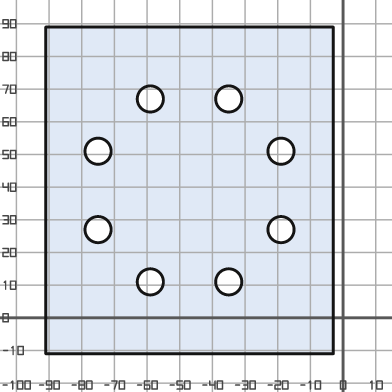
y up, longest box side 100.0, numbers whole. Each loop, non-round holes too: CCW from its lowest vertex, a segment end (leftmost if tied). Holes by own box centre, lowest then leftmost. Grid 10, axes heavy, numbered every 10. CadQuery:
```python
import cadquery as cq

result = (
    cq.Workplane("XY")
    .moveTo(-91.0, -11.0)
    .lineTo(-3.0, -11.0)
    .lineTo(-3.0, 89.0)
    .lineTo(-91.0, 89.0)
    .close()
    .moveTo(-59.0, 11.0)
    .circle(4.0)
    .moveTo(-35.0, 11.0)
    .circle(4.0)
    .moveTo(-75.0, 27.0)
    .circle(4.0)
    .moveTo(-19.0, 27.0)
    .circle(4.0)
    .moveTo(-75.0, 51.0)
    .circle(4.0)
    .moveTo(-19.0, 51.0)
    .circle(4.0)
    .moveTo(-59.0, 67.0)
    .circle(4.0)
    .moveTo(-35.0, 67.0)
    .circle(4.0)
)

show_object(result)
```